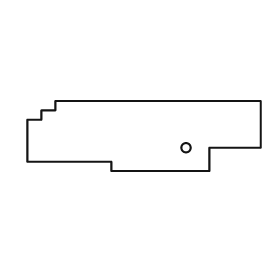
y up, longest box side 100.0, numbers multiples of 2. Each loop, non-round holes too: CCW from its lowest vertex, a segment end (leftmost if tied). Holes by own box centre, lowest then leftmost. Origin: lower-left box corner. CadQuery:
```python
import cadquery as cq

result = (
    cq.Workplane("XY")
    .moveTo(36.0, 0.0)
    .lineTo(78.0, 0.0)
    .lineTo(78.0, 10.0)
    .lineTo(100.0, 10.0)
    .lineTo(100.0, 30.0)
    .lineTo(12.0, 30.0)
    .lineTo(12.0, 26.0)
    .lineTo(6.0, 26.0)
    .lineTo(6.0, 22.0)
    .lineTo(0.0, 22.0)
    .lineTo(0.0, 4.0)
    .lineTo(36.0, 4.0)
    .close()
    .moveTo(68.0, 10.0)
    .circle(2.0)
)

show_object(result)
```